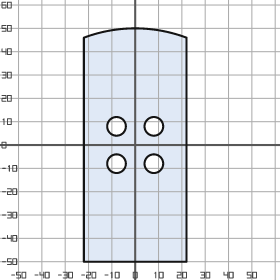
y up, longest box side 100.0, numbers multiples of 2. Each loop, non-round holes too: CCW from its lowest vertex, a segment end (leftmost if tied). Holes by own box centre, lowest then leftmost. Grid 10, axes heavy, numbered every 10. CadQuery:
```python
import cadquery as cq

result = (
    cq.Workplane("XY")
    .moveTo(-22.0, -50.0)
    .lineTo(22.0, -50.0)
    .lineTo(22.0, 46.0)
    .threePointArc((0.0, 50.0), (-22.0, 46.0))
    .close()
    .moveTo(-8.0, -8.0)
    .circle(4.0)
    .moveTo(8.0, -8.0)
    .circle(4.0)
    .moveTo(-8.0, 8.0)
    .circle(4.0)
    .moveTo(8.0, 8.0)
    .circle(4.0)
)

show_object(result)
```